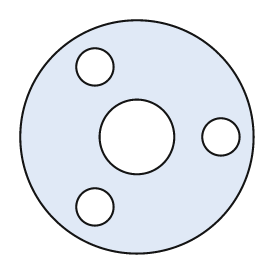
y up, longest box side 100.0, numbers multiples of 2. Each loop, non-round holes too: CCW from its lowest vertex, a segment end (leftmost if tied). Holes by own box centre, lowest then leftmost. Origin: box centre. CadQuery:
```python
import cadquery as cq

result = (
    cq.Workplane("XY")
    .moveTo(0.0, 0.0)
    .circle(50.0)
    .moveTo(-18.0, -30.0)
    .circle(8.0)
    .moveTo(0.0, 0.0)
    .circle(16.0)
    .moveTo(36.0, 0.0)
    .circle(8.0)
    .moveTo(-18.0, 30.0)
    .circle(8.0)
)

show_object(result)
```